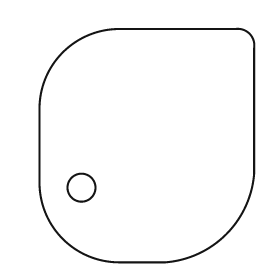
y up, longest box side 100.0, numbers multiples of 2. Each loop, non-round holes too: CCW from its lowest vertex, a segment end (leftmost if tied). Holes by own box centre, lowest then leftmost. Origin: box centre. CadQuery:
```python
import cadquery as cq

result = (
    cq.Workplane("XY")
    .moveTo(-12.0, -50.0)
    .lineTo(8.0, -50.0)
    .threePointArc((34.0, -38.0), (46.0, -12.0))
    .lineTo(46.0, 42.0)
    .threePointArc((44.0, 48.0), (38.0, 50.0))
    .lineTo(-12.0, 50.0)
    .threePointArc((-36.0, 40.0), (-46.0, 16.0))
    .lineTo(-46.0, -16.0)
    .threePointArc((-36.0, -40.0), (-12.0, -50.0))
    .close()
    .moveTo(-28.0, -18.0)
    .circle(6.0)
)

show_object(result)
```